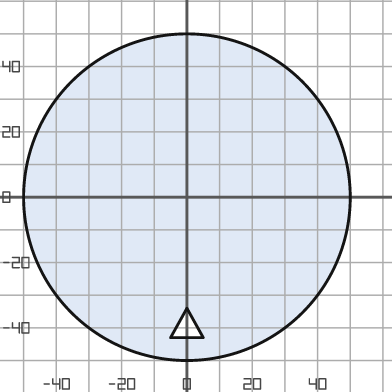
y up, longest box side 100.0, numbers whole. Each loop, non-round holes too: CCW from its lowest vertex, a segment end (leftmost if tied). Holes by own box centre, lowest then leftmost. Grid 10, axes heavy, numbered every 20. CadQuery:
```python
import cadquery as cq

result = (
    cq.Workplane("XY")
    .moveTo(0.0, 0.0)
    .circle(50.0)
    .moveTo(-5.0, -43.0)
    .lineTo(5.0, -43.0)
    .lineTo(0.0, -34.0)
    .close()
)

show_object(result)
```